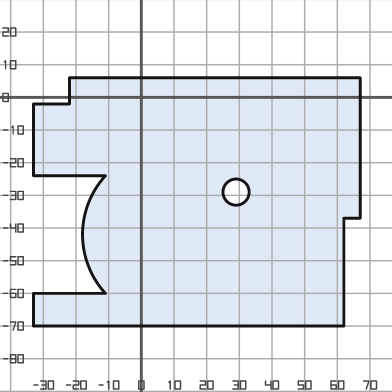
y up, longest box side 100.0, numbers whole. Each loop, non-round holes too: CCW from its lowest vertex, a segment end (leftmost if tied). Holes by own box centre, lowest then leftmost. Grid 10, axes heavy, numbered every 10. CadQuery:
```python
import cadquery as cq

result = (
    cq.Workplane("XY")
    .moveTo(-33.0, -70.0)
    .lineTo(62.0, -70.0)
    .lineTo(62.0, -37.0)
    .lineTo(67.0, -37.0)
    .lineTo(67.0, 6.0)
    .lineTo(-22.0, 6.0)
    .lineTo(-22.0, -2.0)
    .lineTo(-33.0, -2.0)
    .lineTo(-33.0, -24.0)
    .lineTo(-11.0, -24.0)
    .threePointArc((-18.0, -42.0), (-11.0, -60.0))
    .lineTo(-33.0, -60.0)
    .close()
    .moveTo(29.0, -29.0)
    .circle(4.0)
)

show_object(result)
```